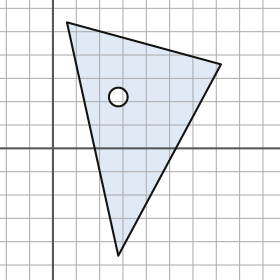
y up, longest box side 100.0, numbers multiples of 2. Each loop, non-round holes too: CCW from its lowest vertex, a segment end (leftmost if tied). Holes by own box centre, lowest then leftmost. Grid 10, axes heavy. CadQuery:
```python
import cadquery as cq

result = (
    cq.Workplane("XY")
    .moveTo(28.0, -46.0)
    .lineTo(72.0, 36.0)
    .lineTo(6.0, 54.0)
    .close()
    .moveTo(28.0, 22.0)
    .circle(4.0)
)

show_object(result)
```